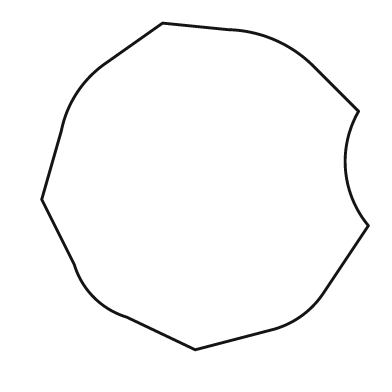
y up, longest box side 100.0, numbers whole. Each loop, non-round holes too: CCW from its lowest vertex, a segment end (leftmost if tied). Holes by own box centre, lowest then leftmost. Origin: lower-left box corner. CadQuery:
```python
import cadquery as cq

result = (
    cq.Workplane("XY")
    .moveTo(47.0, 0.0)
    .lineTo(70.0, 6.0)
    .threePointArc((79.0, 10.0), (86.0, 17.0))
    .lineTo(100.0, 38.0)
    .threePointArc((93.0, 55.0), (97.0, 73.0))
    .lineTo(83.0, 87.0)
    .threePointArc((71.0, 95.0), (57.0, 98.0))
    .lineTo(37.0, 100.0)
    .lineTo(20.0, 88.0)
    .threePointArc((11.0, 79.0), (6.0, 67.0))
    .lineTo(0.0, 46.0)
    .lineTo(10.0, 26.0)
    .threePointArc((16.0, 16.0), (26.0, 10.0))
    .close()
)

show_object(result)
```